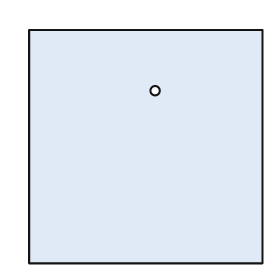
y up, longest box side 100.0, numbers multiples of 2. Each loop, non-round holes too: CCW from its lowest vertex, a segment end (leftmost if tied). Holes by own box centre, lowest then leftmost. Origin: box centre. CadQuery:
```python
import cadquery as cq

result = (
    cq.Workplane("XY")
    .moveTo(-50.0, -50.0)
    .lineTo(50.0, -50.0)
    .lineTo(50.0, 50.0)
    .lineTo(-50.0, 50.0)
    .close()
    .moveTo(4.0, 24.0)
    .circle(2.0)
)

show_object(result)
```